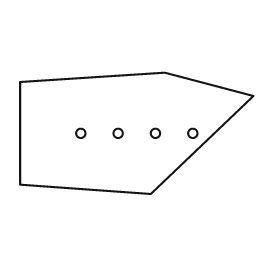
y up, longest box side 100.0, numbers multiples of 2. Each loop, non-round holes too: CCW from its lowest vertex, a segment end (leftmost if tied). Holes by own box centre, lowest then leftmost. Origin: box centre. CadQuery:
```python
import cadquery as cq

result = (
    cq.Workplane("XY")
    .moveTo(6.0, -26.0)
    .lineTo(50.0, 16.0)
    .lineTo(12.0, 26.0)
    .lineTo(-50.0, 22.0)
    .lineTo(-50.0, -22.0)
    .close()
    .moveTo(-24.0, 0.0)
    .circle(2.0)
    .moveTo(-8.0, 0.0)
    .circle(2.0)
    .moveTo(8.0, 0.0)
    .circle(2.0)
    .moveTo(24.0, 0.0)
    .circle(2.0)
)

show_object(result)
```